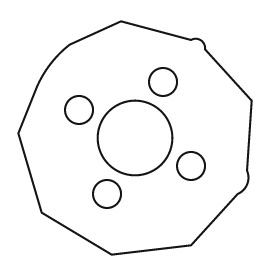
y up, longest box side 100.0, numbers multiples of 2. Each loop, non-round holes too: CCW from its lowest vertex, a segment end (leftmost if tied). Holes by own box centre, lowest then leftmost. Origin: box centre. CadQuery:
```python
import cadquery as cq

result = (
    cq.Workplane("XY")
    .moveTo(-10.0, -50.0)
    .lineTo(24.0, -46.0)
    .lineTo(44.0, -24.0)
    .threePointArc((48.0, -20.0), (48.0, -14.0))
    .lineTo(50.0, 16.0)
    .lineTo(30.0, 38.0)
    .threePointArc((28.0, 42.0), (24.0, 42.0))
    .lineTo(-6.0, 50.0)
    .lineTo(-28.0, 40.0)
    .threePointArc((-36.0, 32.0), (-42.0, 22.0))
    .lineTo(-50.0, 2.0)
    .lineTo(-40.0, -32.0)
    .close()
    .moveTo(-12.0, -24.0)
    .circle(6.0)
    .moveTo(24.0, -12.0)
    .circle(6.0)
    .moveTo(0.0, 0.0)
    .circle(16.0)
    .moveTo(-24.0, 12.0)
    .circle(6.0)
    .moveTo(12.0, 24.0)
    .circle(6.0)
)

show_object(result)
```